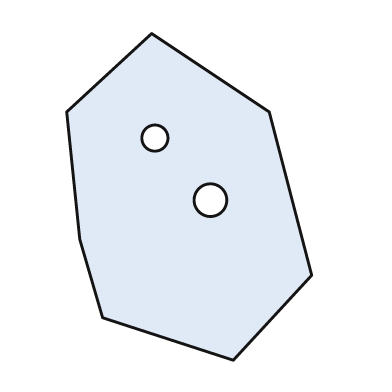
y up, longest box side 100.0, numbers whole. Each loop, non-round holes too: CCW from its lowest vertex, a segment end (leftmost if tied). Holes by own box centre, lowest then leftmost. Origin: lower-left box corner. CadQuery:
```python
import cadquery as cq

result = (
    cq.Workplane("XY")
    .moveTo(51.0, 0.0)
    .lineTo(75.0, 26.0)
    .lineTo(62.0, 76.0)
    .lineTo(26.0, 100.0)
    .lineTo(0.0, 76.0)
    .lineTo(4.0, 37.0)
    .lineTo(11.0, 13.0)
    .close()
    .moveTo(44.0, 49.0)
    .circle(5.0)
    .moveTo(27.0, 68.0)
    .circle(4.0)
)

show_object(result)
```